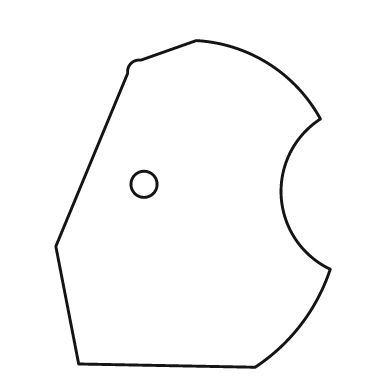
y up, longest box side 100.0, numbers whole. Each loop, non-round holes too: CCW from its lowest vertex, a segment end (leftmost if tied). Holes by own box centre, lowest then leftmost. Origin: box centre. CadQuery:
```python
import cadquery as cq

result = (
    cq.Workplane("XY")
    .moveTo(19.0, -50.0)
    .threePointArc((33.0, -37.0), (42.0, -20.0))
    .threePointArc((27.0, 2.0), (39.0, 26.0))
    .threePointArc((23.0, 43.0), (1.0, 50.0))
    .lineTo(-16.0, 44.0)
    .threePointArc((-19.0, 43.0), (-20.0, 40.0))
    .lineTo(-42.0, -13.0)
    .lineTo(-35.0, -49.0)
    .close()
    .moveTo(-15.0, 6.0)
    .circle(4.0)
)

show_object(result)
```